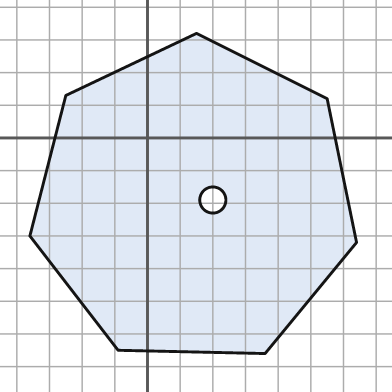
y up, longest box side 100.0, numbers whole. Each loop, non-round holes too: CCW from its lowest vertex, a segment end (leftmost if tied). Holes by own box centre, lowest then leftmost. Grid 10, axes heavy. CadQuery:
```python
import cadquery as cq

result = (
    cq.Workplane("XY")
    .moveTo(36.0, -66.0)
    .lineTo(64.0, -32.0)
    .lineTo(55.0, 12.0)
    .lineTo(15.0, 32.0)
    .lineTo(-25.0, 13.0)
    .lineTo(-36.0, -30.0)
    .lineTo(-9.0, -65.0)
    .close()
    .moveTo(20.0, -19.0)
    .circle(4.0)
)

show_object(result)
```